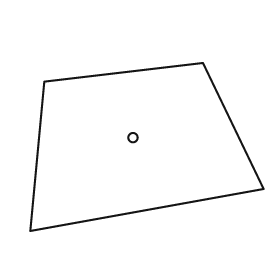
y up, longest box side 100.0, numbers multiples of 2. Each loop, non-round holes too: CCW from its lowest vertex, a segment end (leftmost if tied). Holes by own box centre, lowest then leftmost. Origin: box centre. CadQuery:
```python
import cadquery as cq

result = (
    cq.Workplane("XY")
    .moveTo(-50.0, -36.0)
    .lineTo(50.0, -18.0)
    .lineTo(24.0, 36.0)
    .lineTo(-44.0, 28.0)
    .close()
    .moveTo(-6.0, 4.0)
    .circle(2.0)
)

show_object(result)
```